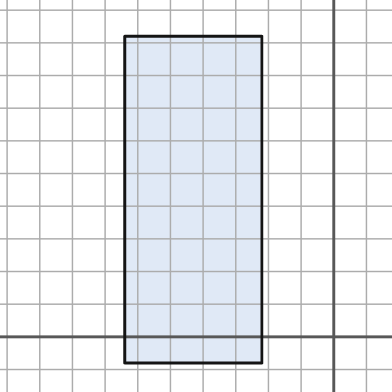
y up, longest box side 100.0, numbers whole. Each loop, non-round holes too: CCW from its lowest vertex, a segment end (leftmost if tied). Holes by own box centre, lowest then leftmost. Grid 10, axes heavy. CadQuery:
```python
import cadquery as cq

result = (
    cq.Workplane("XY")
    .moveTo(-64.0, -8.0)
    .lineTo(-22.0, -8.0)
    .lineTo(-22.0, 92.0)
    .lineTo(-64.0, 92.0)
    .close()
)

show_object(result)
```